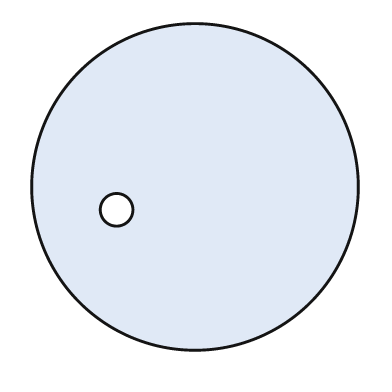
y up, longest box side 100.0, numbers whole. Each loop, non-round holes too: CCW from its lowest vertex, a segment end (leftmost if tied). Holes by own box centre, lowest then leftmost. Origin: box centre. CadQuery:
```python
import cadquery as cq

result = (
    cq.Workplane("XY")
    .moveTo(0.0, 0.0)
    .circle(50.0)
    .moveTo(-24.0, -7.0)
    .circle(5.0)
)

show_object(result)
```